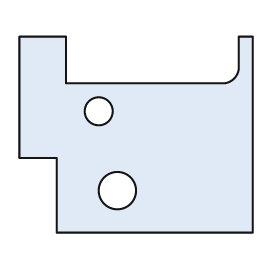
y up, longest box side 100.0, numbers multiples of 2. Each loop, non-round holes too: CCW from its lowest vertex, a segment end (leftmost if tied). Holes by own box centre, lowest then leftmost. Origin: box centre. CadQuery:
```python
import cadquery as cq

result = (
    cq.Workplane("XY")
    .moveTo(-34.0, -42.0)
    .lineTo(50.0, -42.0)
    .lineTo(50.0, 42.0)
    .lineTo(44.0, 42.0)
    .lineTo(44.0, 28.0)
    .threePointArc((42.0, 24.0), (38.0, 22.0))
    .lineTo(-30.0, 22.0)
    .lineTo(-30.0, 42.0)
    .lineTo(-50.0, 42.0)
    .lineTo(-50.0, -10.0)
    .lineTo(-34.0, -10.0)
    .close()
    .moveTo(-8.0, -24.0)
    .circle(8.0)
    .moveTo(-16.0, 10.0)
    .circle(6.0)
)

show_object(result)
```